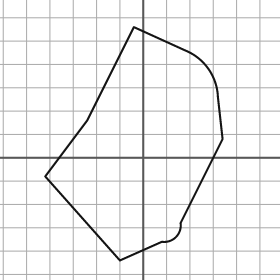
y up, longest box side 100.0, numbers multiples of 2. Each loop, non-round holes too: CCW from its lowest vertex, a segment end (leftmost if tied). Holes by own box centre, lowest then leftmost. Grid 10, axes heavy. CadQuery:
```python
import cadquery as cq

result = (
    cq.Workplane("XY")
    .moveTo(-10.0, -44.0)
    .lineTo(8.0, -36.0)
    .threePointArc((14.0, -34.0), (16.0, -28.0))
    .lineTo(34.0, 8.0)
    .lineTo(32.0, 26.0)
    .threePointArc((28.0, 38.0), (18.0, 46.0))
    .lineTo(-4.0, 56.0)
    .lineTo(-24.0, 16.0)
    .lineTo(-42.0, -8.0)
    .close()
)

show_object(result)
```